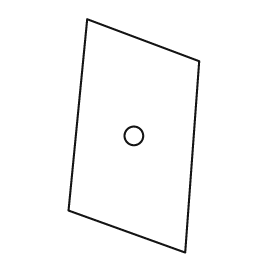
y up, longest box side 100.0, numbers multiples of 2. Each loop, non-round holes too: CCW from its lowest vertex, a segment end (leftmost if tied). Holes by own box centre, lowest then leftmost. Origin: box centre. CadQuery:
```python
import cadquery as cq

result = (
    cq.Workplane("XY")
    .moveTo(22.0, -50.0)
    .lineTo(28.0, 32.0)
    .lineTo(-20.0, 50.0)
    .lineTo(-28.0, -32.0)
    .close()
    .moveTo(0.0, 0.0)
    .circle(4.0)
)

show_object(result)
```